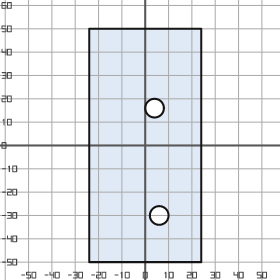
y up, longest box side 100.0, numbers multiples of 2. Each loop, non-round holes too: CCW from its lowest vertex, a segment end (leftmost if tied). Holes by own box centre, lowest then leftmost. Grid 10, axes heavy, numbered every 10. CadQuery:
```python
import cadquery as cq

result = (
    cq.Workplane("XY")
    .moveTo(-24.0, -50.0)
    .lineTo(24.0, -50.0)
    .lineTo(24.0, 50.0)
    .lineTo(-24.0, 50.0)
    .close()
    .moveTo(6.0, -30.0)
    .circle(4.0)
    .moveTo(4.0, 16.0)
    .circle(4.0)
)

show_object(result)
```